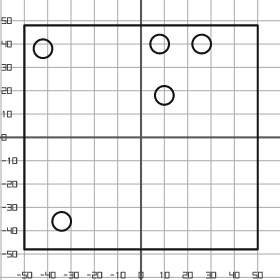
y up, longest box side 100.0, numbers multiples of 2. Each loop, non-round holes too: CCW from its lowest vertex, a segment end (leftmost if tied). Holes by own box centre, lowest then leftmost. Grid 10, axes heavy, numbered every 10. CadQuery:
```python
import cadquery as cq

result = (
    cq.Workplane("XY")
    .moveTo(-50.0, -48.0)
    .lineTo(50.0, -48.0)
    .lineTo(50.0, 48.0)
    .lineTo(-50.0, 48.0)
    .close()
    .moveTo(-34.0, -36.0)
    .circle(4.0)
    .moveTo(10.0, 18.0)
    .circle(4.0)
    .moveTo(-42.0, 38.0)
    .circle(4.0)
    .moveTo(8.0, 40.0)
    .circle(4.0)
    .moveTo(26.0, 40.0)
    .circle(4.0)
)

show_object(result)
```